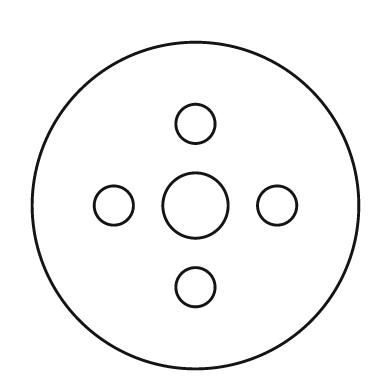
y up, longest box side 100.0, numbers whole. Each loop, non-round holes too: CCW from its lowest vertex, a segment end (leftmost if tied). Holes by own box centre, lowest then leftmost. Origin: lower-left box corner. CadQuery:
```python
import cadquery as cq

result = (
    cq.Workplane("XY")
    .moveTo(50.0, 50.0)
    .circle(50.0)
    .moveTo(50.0, 25.0)
    .circle(6.0)
    .moveTo(25.0, 50.0)
    .circle(6.0)
    .moveTo(50.0, 50.0)
    .circle(10.0)
    .moveTo(75.0, 50.0)
    .circle(6.0)
    .moveTo(50.0, 75.0)
    .circle(6.0)
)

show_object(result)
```